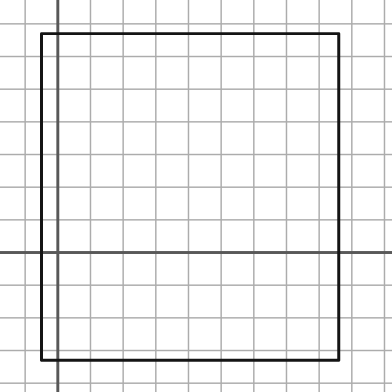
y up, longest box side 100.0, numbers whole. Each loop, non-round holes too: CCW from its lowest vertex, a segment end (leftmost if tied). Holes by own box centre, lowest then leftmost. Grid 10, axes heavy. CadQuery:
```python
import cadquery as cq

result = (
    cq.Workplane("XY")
    .moveTo(-5.0, -33.0)
    .lineTo(86.0, -33.0)
    .lineTo(86.0, 67.0)
    .lineTo(-5.0, 67.0)
    .close()
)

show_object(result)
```